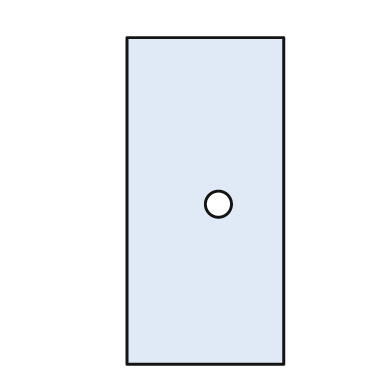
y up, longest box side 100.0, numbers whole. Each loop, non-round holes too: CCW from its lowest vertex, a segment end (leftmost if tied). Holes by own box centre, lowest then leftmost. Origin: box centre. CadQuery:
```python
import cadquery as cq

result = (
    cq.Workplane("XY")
    .moveTo(-24.0, -50.0)
    .lineTo(24.0, -50.0)
    .lineTo(24.0, 50.0)
    .lineTo(-24.0, 50.0)
    .close()
    .moveTo(4.0, -1.0)
    .circle(4.0)
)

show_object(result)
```